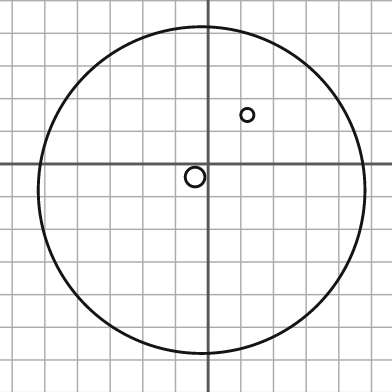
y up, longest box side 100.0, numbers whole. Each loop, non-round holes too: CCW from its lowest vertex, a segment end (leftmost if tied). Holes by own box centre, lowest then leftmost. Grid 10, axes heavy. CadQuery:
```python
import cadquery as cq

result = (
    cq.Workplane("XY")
    .moveTo(-2.0, -8.0)
    .circle(50.0)
    .moveTo(-4.0, -4.0)
    .circle(3.0)
    .moveTo(12.0, 15.0)
    .circle(2.0)
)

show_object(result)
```